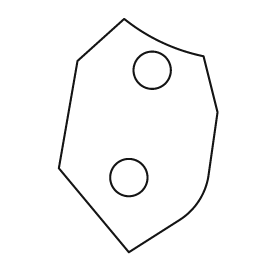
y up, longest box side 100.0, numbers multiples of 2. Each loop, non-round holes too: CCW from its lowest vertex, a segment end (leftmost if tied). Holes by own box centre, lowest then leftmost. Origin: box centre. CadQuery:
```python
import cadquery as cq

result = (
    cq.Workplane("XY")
    .moveTo(-4.0, -50.0)
    .lineTo(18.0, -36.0)
    .threePointArc((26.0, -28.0), (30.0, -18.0))
    .lineTo(34.0, 10.0)
    .lineTo(28.0, 34.0)
    .threePointArc((10.0, 40.0), (-6.0, 50.0))
    .lineTo(-26.0, 32.0)
    .lineTo(-34.0, -14.0)
    .close()
    .moveTo(-4.0, -18.0)
    .circle(8.0)
    .moveTo(6.0, 28.0)
    .circle(8.0)
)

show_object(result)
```